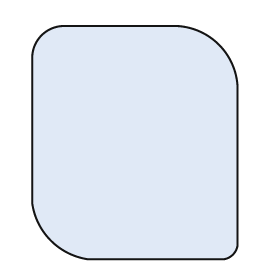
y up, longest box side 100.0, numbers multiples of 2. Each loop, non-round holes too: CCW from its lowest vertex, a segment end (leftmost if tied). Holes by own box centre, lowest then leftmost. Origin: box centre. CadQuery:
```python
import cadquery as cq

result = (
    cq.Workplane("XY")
    .moveTo(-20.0, -50.0)
    .lineTo(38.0, -50.0)
    .threePointArc((42.0, -48.0), (44.0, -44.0))
    .lineTo(44.0, 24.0)
    .threePointArc((36.0, 42.0), (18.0, 50.0))
    .lineTo(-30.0, 50.0)
    .threePointArc((-40.0, 46.0), (-44.0, 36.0))
    .lineTo(-44.0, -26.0)
    .threePointArc((-36.0, -42.0), (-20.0, -50.0))
    .close()
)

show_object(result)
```